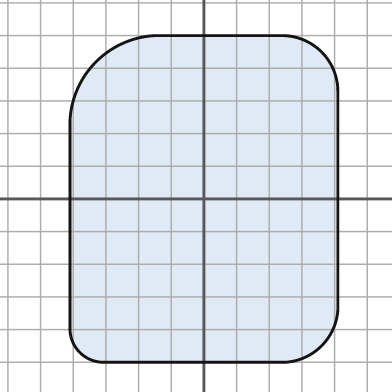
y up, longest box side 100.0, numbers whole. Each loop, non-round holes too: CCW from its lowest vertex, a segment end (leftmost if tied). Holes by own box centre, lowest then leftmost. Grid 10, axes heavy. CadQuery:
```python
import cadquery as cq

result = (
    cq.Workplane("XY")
    .moveTo(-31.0, -50.0)
    .lineTo(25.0, -50.0)
    .threePointArc((36.0, -45.0), (41.0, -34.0))
    .lineTo(41.0, 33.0)
    .threePointArc((36.0, 45.0), (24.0, 50.0))
    .lineTo(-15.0, 50.0)
    .threePointArc((-33.0, 42.0), (-41.0, 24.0))
    .lineTo(-41.0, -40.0)
    .threePointArc((-38.0, -47.0), (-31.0, -50.0))
    .close()
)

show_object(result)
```